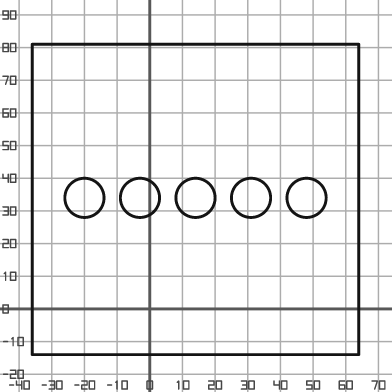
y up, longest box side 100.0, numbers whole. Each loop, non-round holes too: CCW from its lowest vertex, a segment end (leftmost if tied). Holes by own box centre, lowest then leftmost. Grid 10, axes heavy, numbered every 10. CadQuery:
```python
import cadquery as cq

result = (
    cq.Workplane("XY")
    .moveTo(-36.0, -14.0)
    .lineTo(64.0, -14.0)
    .lineTo(64.0, 81.0)
    .lineTo(-36.0, 81.0)
    .close()
    .moveTo(-20.0, 34.0)
    .circle(6.0)
    .moveTo(-3.0, 34.0)
    .circle(6.0)
    .moveTo(14.0, 34.0)
    .circle(6.0)
    .moveTo(31.0, 34.0)
    .circle(6.0)
    .moveTo(48.0, 34.0)
    .circle(6.0)
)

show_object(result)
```